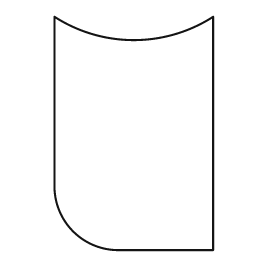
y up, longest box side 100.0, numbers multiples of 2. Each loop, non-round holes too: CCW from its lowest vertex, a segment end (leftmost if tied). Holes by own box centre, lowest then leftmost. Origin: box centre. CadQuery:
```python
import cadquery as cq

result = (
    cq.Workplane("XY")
    .moveTo(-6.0, -50.0)
    .lineTo(34.0, -50.0)
    .lineTo(34.0, 50.0)
    .threePointArc((0.0, 40.0), (-34.0, 50.0))
    .lineTo(-34.0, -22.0)
    .threePointArc((-26.0, -42.0), (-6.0, -50.0))
    .close()
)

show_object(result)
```